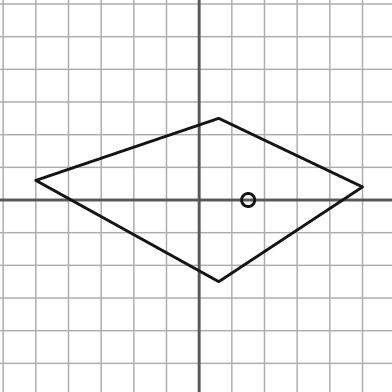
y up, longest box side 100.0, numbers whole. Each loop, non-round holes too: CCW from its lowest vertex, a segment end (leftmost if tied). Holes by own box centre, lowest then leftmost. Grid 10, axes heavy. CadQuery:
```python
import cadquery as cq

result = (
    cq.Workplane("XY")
    .moveTo(6.0, -25.0)
    .lineTo(50.0, 4.0)
    .lineTo(6.0, 25.0)
    .lineTo(-50.0, 6.0)
    .close()
    .moveTo(15.0, 0.0)
    .circle(2.0)
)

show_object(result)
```